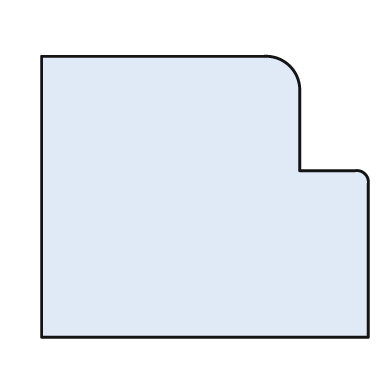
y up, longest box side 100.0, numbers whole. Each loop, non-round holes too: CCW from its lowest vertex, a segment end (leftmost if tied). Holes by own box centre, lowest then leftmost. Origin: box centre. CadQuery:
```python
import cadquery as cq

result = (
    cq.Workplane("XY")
    .moveTo(-50.0, -43.0)
    .lineTo(50.0, -43.0)
    .lineTo(50.0, 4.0)
    .threePointArc((49.0, 7.0), (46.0, 8.0))
    .lineTo(29.0, 8.0)
    .lineTo(29.0, 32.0)
    .threePointArc((26.0, 40.0), (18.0, 43.0))
    .lineTo(-50.0, 43.0)
    .close()
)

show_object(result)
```